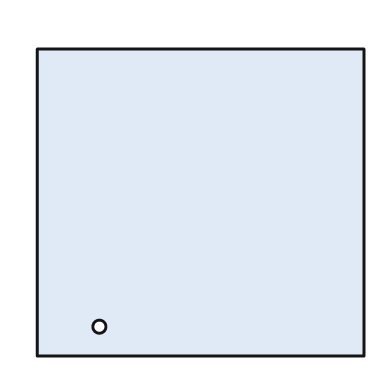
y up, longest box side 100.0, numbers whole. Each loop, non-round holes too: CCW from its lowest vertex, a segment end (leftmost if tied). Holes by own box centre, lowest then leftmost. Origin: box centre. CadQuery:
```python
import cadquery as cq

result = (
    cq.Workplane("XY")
    .moveTo(-50.0, -47.0)
    .lineTo(50.0, -47.0)
    .lineTo(50.0, 47.0)
    .lineTo(-50.0, 47.0)
    .close()
    .moveTo(-31.0, -38.0)
    .circle(2.0)
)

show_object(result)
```